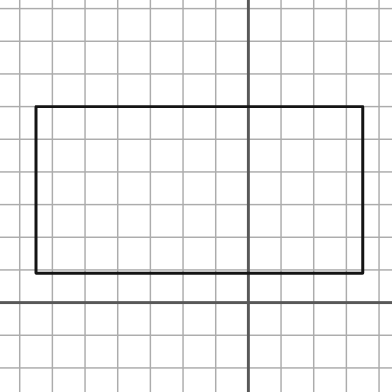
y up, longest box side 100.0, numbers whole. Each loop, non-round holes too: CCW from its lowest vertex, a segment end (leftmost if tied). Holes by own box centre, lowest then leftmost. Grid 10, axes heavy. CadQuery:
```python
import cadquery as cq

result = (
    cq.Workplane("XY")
    .moveTo(-65.0, 9.0)
    .lineTo(35.0, 9.0)
    .lineTo(35.0, 60.0)
    .lineTo(-65.0, 60.0)
    .close()
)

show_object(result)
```